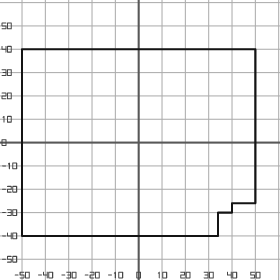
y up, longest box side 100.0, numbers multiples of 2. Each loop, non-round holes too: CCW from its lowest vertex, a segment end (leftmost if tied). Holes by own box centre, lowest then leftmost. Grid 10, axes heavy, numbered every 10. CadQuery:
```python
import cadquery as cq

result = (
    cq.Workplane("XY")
    .moveTo(-50.0, -40.0)
    .lineTo(34.0, -40.0)
    .lineTo(34.0, -30.0)
    .lineTo(40.0, -30.0)
    .lineTo(40.0, -26.0)
    .lineTo(50.0, -26.0)
    .lineTo(50.0, 40.0)
    .lineTo(-50.0, 40.0)
    .close()
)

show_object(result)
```